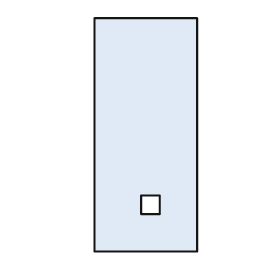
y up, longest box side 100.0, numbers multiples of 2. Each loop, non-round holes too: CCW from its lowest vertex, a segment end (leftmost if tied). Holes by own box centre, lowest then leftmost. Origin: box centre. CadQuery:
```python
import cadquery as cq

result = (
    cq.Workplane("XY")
    .moveTo(-22.0, -50.0)
    .lineTo(22.0, -50.0)
    .lineTo(22.0, 50.0)
    .lineTo(-22.0, 50.0)
    .close()
    .moveTo(-2.0, -34.0)
    .lineTo(6.0, -34.0)
    .lineTo(6.0, -26.0)
    .lineTo(-2.0, -26.0)
    .close()
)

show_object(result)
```